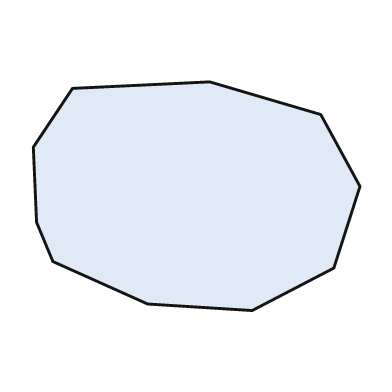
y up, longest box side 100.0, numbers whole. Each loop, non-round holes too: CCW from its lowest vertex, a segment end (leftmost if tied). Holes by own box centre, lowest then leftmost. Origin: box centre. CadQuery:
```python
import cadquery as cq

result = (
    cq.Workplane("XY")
    .moveTo(17.0, -35.0)
    .lineTo(42.0, -22.0)
    .lineTo(50.0, 3.0)
    .lineTo(38.0, 25.0)
    .lineTo(4.0, 35.0)
    .lineTo(-38.0, 33.0)
    .lineTo(-50.0, 15.0)
    .lineTo(-49.0, -8.0)
    .lineTo(-44.0, -20.0)
    .lineTo(-15.0, -33.0)
    .close()
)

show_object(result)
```